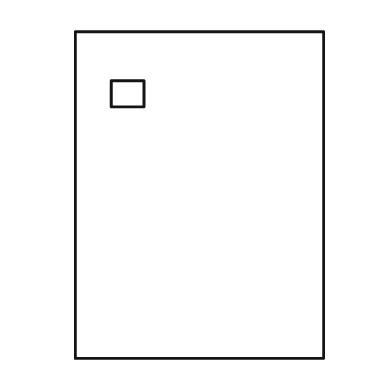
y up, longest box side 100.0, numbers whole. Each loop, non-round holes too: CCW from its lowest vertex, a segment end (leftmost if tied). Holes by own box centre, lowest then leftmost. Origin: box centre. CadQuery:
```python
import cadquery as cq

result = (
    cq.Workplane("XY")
    .moveTo(-38.0, -50.0)
    .lineTo(38.0, -50.0)
    .lineTo(38.0, 50.0)
    .lineTo(-38.0, 50.0)
    .close()
    .moveTo(-27.0, 27.0)
    .lineTo(-17.0, 27.0)
    .lineTo(-17.0, 35.0)
    .lineTo(-27.0, 35.0)
    .close()
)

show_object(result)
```